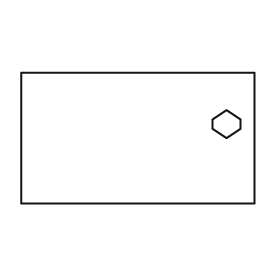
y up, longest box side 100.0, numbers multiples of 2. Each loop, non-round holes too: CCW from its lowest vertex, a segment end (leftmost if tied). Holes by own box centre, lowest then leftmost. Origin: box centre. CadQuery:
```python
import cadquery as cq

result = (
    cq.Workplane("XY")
    .moveTo(-50.0, -28.0)
    .lineTo(50.0, -28.0)
    .lineTo(50.0, 28.0)
    .lineTo(-50.0, 28.0)
    .close()
    .moveTo(38.0, 0.0)
    .lineTo(44.0, 4.0)
    .lineTo(44.0, 8.0)
    .lineTo(38.0, 12.0)
    .lineTo(32.0, 8.0)
    .lineTo(32.0, 4.0)
    .close()
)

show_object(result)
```